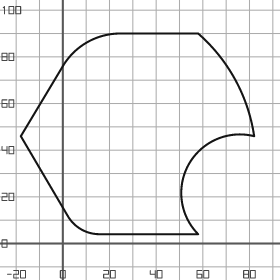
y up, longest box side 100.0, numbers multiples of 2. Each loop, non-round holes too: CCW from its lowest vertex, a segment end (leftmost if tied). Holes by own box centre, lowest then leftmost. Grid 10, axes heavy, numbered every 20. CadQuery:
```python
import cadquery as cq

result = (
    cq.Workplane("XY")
    .moveTo(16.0, 4.0)
    .lineTo(58.0, 4.0)
    .threePointArc((54.0, 34.0), (82.0, 46.0))
    .threePointArc((74.0, 70.0), (58.0, 90.0))
    .lineTo(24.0, 90.0)
    .threePointArc((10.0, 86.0), (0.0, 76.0))
    .lineTo(-18.0, 46.0)
    .lineTo(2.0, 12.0)
    .threePointArc((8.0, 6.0), (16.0, 4.0))
    .close()
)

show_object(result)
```